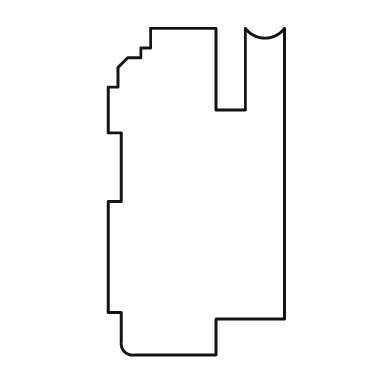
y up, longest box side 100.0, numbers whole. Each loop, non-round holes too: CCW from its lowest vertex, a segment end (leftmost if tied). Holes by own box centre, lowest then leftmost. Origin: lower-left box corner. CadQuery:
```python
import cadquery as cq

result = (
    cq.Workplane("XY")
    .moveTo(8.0, 0.0)
    .lineTo(33.0, 0.0)
    .lineTo(33.0, 11.0)
    .lineTo(54.0, 11.0)
    .lineTo(54.0, 100.0)
    .threePointArc((48.0, 97.0), (42.0, 100.0))
    .lineTo(42.0, 75.0)
    .lineTo(33.0, 75.0)
    .lineTo(33.0, 100.0)
    .lineTo(13.0, 100.0)
    .lineTo(13.0, 94.0)
    .lineTo(10.0, 94.0)
    .lineTo(10.0, 91.0)
    .lineTo(6.0, 91.0)
    .lineTo(3.0, 88.0)
    .lineTo(3.0, 82.0)
    .lineTo(0.0, 82.0)
    .lineTo(0.0, 68.0)
    .lineTo(4.0, 68.0)
    .lineTo(4.0, 47.0)
    .lineTo(0.0, 47.0)
    .lineTo(0.0, 13.0)
    .lineTo(4.0, 13.0)
    .lineTo(4.0, 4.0)
    .threePointArc((5.0, 1.0), (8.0, 0.0))
    .close()
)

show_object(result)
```